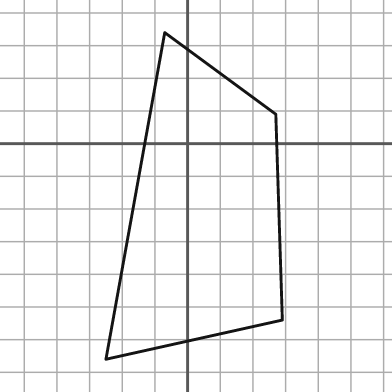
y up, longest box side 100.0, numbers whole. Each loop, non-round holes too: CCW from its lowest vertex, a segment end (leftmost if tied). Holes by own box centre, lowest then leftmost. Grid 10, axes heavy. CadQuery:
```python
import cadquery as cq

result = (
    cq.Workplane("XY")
    .moveTo(-25.0, -66.0)
    .lineTo(29.0, -54.0)
    .lineTo(27.0, 9.0)
    .lineTo(-7.0, 34.0)
    .close()
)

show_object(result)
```